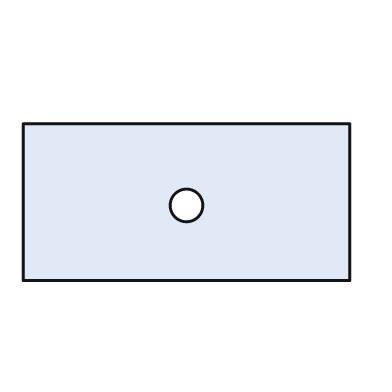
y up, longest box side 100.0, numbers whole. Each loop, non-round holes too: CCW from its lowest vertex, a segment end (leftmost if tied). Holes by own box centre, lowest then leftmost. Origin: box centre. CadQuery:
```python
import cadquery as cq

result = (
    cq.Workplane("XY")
    .moveTo(-50.0, -24.0)
    .lineTo(50.0, -24.0)
    .lineTo(50.0, 24.0)
    .lineTo(-50.0, 24.0)
    .close()
    .moveTo(0.0, -1.0)
    .circle(5.0)
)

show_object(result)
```